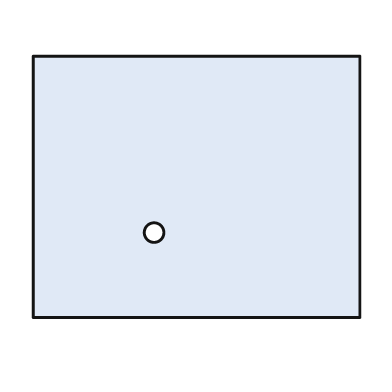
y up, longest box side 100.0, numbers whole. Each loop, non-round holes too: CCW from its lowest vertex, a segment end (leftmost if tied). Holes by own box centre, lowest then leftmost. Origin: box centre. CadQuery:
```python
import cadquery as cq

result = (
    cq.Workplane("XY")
    .moveTo(-50.0, -40.0)
    .lineTo(50.0, -40.0)
    .lineTo(50.0, 40.0)
    .lineTo(-50.0, 40.0)
    .close()
    .moveTo(-13.0, -14.0)
    .circle(3.0)
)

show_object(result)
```